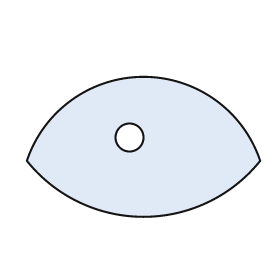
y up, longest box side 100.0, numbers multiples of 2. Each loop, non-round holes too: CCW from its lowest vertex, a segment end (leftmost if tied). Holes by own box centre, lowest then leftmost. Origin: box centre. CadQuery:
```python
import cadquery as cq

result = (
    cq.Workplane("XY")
    .moveTo(-50.0, -6.0)
    .threePointArc((0.0, -30.0), (50.0, -6.0))
    .threePointArc((0.0, 30.0), (-50.0, -6.0))
    .close()
    .moveTo(-6.0, 4.0)
    .circle(6.0)
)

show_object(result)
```